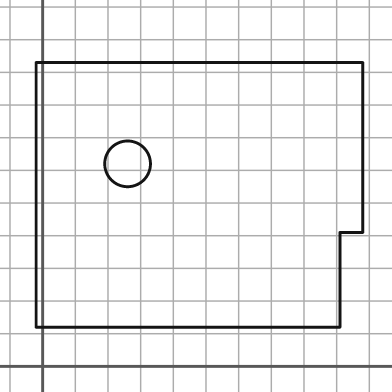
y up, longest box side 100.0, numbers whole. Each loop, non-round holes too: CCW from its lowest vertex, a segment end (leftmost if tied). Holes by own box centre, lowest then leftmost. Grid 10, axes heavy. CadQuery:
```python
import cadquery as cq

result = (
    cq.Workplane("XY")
    .moveTo(-2.0, 12.0)
    .lineTo(91.0, 12.0)
    .lineTo(91.0, 41.0)
    .lineTo(98.0, 41.0)
    .lineTo(98.0, 93.0)
    .lineTo(-2.0, 93.0)
    .close()
    .moveTo(26.0, 62.0)
    .circle(7.0)
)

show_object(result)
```